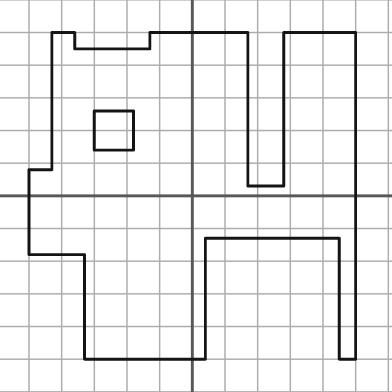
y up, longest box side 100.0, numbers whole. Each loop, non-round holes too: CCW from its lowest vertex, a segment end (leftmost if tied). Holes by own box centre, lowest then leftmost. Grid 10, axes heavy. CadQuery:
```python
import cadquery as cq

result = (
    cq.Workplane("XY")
    .moveTo(-33.0, -50.0)
    .lineTo(4.0, -50.0)
    .lineTo(4.0, -13.0)
    .lineTo(45.0, -13.0)
    .lineTo(45.0, -50.0)
    .lineTo(50.0, -50.0)
    .lineTo(50.0, 50.0)
    .lineTo(28.0, 50.0)
    .lineTo(28.0, 3.0)
    .lineTo(17.0, 3.0)
    .lineTo(17.0, 50.0)
    .lineTo(-13.0, 50.0)
    .lineTo(-13.0, 45.0)
    .lineTo(-36.0, 45.0)
    .lineTo(-36.0, 50.0)
    .lineTo(-43.0, 50.0)
    .lineTo(-43.0, 8.0)
    .lineTo(-50.0, 8.0)
    .lineTo(-50.0, -18.0)
    .lineTo(-33.0, -18.0)
    .close()
    .moveTo(-30.0, 14.0)
    .lineTo(-18.0, 14.0)
    .lineTo(-18.0, 26.0)
    .lineTo(-30.0, 26.0)
    .close()
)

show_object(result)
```